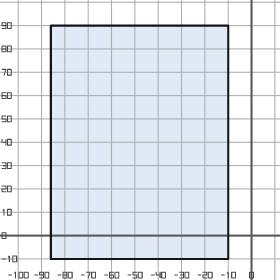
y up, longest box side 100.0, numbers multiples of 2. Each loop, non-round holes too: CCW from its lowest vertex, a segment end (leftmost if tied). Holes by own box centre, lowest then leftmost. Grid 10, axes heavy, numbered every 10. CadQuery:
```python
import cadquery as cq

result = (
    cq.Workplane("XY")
    .moveTo(-86.0, -10.0)
    .lineTo(-10.0, -10.0)
    .lineTo(-10.0, 90.0)
    .lineTo(-86.0, 90.0)
    .close()
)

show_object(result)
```